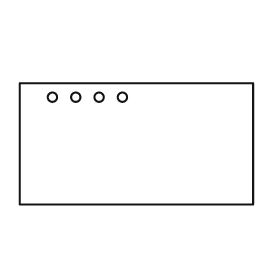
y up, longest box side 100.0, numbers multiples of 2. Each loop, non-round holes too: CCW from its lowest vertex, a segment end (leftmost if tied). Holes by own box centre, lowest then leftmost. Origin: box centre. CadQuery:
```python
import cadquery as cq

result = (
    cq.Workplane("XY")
    .moveTo(-50.0, -26.0)
    .lineTo(50.0, -26.0)
    .lineTo(50.0, 26.0)
    .lineTo(-50.0, 26.0)
    .close()
    .moveTo(-36.0, 20.0)
    .circle(2.0)
    .moveTo(-26.0, 20.0)
    .circle(2.0)
    .moveTo(-16.0, 20.0)
    .circle(2.0)
    .moveTo(-6.0, 20.0)
    .circle(2.0)
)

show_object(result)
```